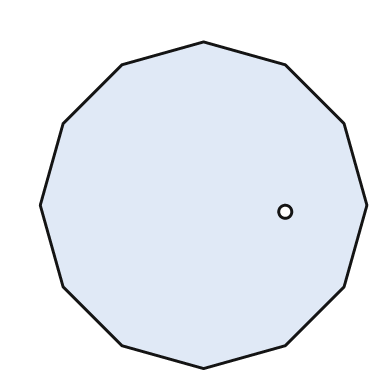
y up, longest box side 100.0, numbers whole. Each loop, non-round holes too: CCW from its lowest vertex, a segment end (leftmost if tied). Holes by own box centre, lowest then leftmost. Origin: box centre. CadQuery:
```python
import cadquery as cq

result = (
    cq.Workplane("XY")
    .moveTo(0.0, -50.0)
    .lineTo(25.0, -43.0)
    .lineTo(43.0, -25.0)
    .lineTo(50.0, 0.0)
    .lineTo(43.0, 25.0)
    .lineTo(25.0, 43.0)
    .lineTo(0.0, 50.0)
    .lineTo(-25.0, 43.0)
    .lineTo(-43.0, 25.0)
    .lineTo(-50.0, 0.0)
    .lineTo(-43.0, -25.0)
    .lineTo(-25.0, -43.0)
    .close()
    .moveTo(25.0, -2.0)
    .circle(2.0)
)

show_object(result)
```